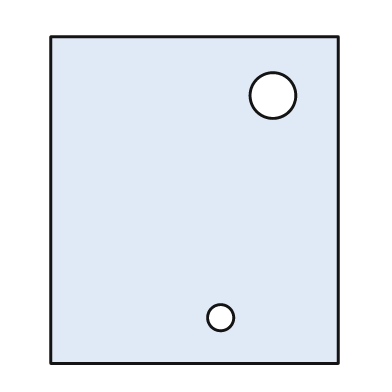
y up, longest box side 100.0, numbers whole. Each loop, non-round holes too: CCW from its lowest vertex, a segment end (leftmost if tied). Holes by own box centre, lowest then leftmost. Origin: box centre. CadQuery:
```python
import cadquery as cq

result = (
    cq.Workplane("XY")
    .moveTo(-44.0, -50.0)
    .lineTo(44.0, -50.0)
    .lineTo(44.0, 50.0)
    .lineTo(-44.0, 50.0)
    .close()
    .moveTo(8.0, -36.0)
    .circle(4.0)
    .moveTo(24.0, 32.0)
    .circle(7.0)
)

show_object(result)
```